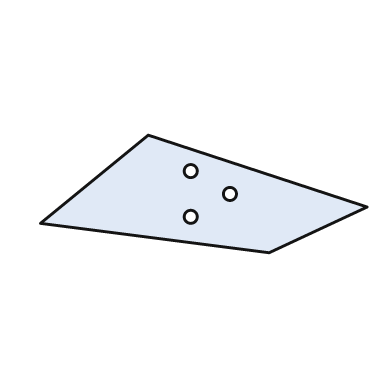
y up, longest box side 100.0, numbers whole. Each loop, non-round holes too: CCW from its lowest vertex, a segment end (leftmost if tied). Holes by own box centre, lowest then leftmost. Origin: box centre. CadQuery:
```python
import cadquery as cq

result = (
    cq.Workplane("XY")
    .moveTo(20.0, -18.0)
    .lineTo(50.0, -4.0)
    .lineTo(-17.0, 18.0)
    .lineTo(-50.0, -9.0)
    .close()
    .moveTo(-4.0, -7.0)
    .circle(2.0)
    .moveTo(8.0, 0.0)
    .circle(2.0)
    .moveTo(-4.0, 7.0)
    .circle(2.0)
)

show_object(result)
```